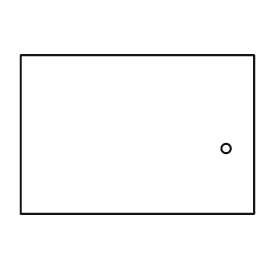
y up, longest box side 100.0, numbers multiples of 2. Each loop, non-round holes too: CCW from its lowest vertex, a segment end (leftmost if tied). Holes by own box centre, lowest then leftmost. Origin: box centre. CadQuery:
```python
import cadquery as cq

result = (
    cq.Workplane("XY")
    .moveTo(-50.0, -34.0)
    .lineTo(50.0, -34.0)
    .lineTo(50.0, 34.0)
    .lineTo(-50.0, 34.0)
    .close()
    .moveTo(38.0, -6.0)
    .circle(2.0)
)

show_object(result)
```